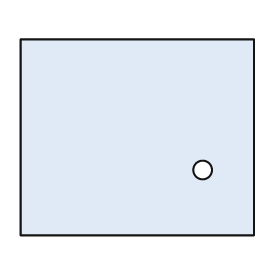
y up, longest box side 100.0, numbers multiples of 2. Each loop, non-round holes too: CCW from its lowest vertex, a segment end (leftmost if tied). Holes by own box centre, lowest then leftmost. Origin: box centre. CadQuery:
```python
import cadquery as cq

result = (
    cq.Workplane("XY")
    .moveTo(-50.0, -42.0)
    .lineTo(50.0, -42.0)
    .lineTo(50.0, 42.0)
    .lineTo(-50.0, 42.0)
    .close()
    .moveTo(28.0, -14.0)
    .circle(4.0)
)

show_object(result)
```